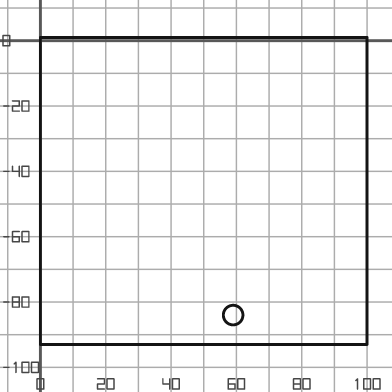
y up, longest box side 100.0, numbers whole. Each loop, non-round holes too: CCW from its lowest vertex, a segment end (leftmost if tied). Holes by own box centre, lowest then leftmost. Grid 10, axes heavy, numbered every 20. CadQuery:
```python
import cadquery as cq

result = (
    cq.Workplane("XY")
    .moveTo(0.0, -93.0)
    .lineTo(100.0, -93.0)
    .lineTo(100.0, 1.0)
    .lineTo(0.0, 1.0)
    .close()
    .moveTo(59.0, -84.0)
    .circle(3.0)
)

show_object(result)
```